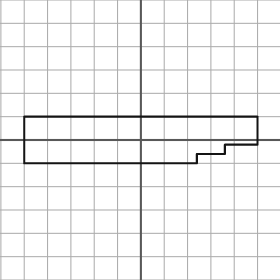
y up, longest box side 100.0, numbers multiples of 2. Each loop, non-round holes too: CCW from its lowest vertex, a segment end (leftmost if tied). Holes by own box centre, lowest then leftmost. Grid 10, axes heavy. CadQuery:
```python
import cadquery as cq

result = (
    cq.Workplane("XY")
    .moveTo(-50.0, -10.0)
    .lineTo(24.0, -10.0)
    .lineTo(24.0, -6.0)
    .lineTo(36.0, -6.0)
    .lineTo(36.0, -2.0)
    .lineTo(50.0, -2.0)
    .lineTo(50.0, 10.0)
    .lineTo(-50.0, 10.0)
    .close()
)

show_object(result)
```